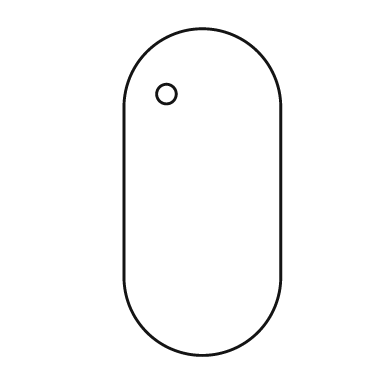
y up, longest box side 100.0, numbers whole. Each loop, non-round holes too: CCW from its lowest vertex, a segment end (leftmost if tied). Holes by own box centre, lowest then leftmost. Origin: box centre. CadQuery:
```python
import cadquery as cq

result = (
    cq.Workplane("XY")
    .moveTo(-24.0, -26.0)
    .threePointArc((0.0, -50.0), (24.0, -26.0))
    .lineTo(24.0, 26.0)
    .threePointArc((0.0, 50.0), (-24.0, 26.0))
    .close()
    .moveTo(-11.0, 30.0)
    .circle(3.0)
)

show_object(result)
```